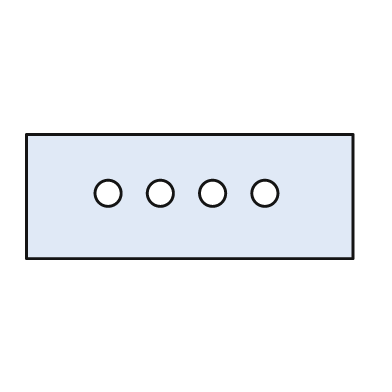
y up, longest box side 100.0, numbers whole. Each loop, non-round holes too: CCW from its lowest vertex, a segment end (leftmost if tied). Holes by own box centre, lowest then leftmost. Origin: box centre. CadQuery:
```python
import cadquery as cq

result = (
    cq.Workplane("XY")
    .moveTo(-50.0, -19.0)
    .lineTo(50.0, -19.0)
    .lineTo(50.0, 19.0)
    .lineTo(-50.0, 19.0)
    .close()
    .moveTo(-25.0, 1.0)
    .circle(4.0)
    .moveTo(-9.0, 1.0)
    .circle(4.0)
    .moveTo(7.0, 1.0)
    .circle(4.0)
    .moveTo(23.0, 1.0)
    .circle(4.0)
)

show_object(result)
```